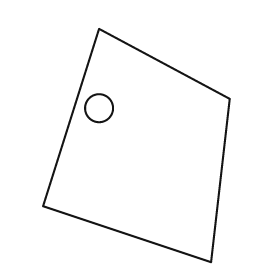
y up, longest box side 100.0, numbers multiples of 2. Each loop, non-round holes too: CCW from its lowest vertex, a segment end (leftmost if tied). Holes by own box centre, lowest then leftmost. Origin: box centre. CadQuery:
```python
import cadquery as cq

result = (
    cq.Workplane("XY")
    .moveTo(32.0, -50.0)
    .lineTo(40.0, 20.0)
    .lineTo(-16.0, 50.0)
    .lineTo(-40.0, -26.0)
    .close()
    .moveTo(-16.0, 16.0)
    .circle(6.0)
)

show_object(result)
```